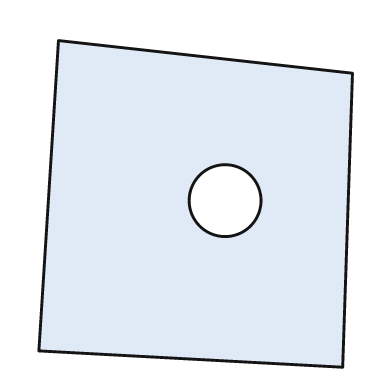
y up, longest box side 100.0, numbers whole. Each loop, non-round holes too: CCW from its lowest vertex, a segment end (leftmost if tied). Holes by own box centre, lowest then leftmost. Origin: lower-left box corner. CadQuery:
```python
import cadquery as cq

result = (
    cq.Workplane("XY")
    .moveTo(93.0, 0.0)
    .lineTo(96.0, 90.0)
    .lineTo(6.0, 100.0)
    .lineTo(0.0, 5.0)
    .close()
    .moveTo(57.0, 51.0)
    .circle(11.0)
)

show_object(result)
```